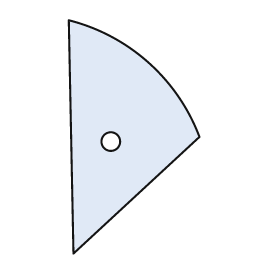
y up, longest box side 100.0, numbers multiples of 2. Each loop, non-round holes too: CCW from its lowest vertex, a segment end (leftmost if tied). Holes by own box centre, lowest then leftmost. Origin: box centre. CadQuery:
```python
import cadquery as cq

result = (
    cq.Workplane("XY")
    .moveTo(-26.0, -50.0)
    .lineTo(28.0, 0.0)
    .threePointArc((6.0, 32.0), (-28.0, 50.0))
    .close()
    .moveTo(-10.0, -2.0)
    .circle(4.0)
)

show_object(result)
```